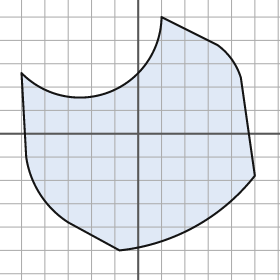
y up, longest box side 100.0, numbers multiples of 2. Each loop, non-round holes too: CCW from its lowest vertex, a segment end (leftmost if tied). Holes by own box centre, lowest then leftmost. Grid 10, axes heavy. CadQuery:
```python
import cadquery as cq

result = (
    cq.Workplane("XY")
    .moveTo(-8.0, -50.0)
    .threePointArc((24.0, -40.0), (50.0, -18.0))
    .lineTo(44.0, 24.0)
    .threePointArc((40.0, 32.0), (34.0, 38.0))
    .lineTo(10.0, 50.0)
    .threePointArc((-12.0, 18.0), (-50.0, 26.0))
    .lineTo(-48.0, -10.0)
    .threePointArc((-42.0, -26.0), (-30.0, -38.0))
    .close()
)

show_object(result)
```